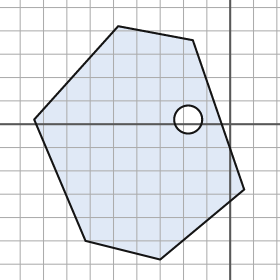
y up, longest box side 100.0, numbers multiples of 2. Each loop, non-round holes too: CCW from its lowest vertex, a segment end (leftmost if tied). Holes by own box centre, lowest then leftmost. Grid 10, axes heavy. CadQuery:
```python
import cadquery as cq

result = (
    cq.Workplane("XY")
    .moveTo(-30.0, -58.0)
    .lineTo(6.0, -28.0)
    .lineTo(-16.0, 36.0)
    .lineTo(-48.0, 42.0)
    .lineTo(-84.0, 2.0)
    .lineTo(-62.0, -50.0)
    .close()
    .moveTo(-18.0, 2.0)
    .circle(6.0)
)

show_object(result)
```